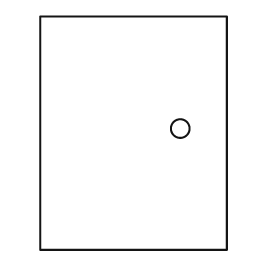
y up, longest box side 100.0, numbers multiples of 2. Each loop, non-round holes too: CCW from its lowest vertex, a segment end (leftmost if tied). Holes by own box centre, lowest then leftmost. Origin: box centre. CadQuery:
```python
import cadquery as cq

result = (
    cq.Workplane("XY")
    .moveTo(-40.0, -50.0)
    .lineTo(40.0, -50.0)
    .lineTo(40.0, 50.0)
    .lineTo(-40.0, 50.0)
    .close()
    .moveTo(20.0, 2.0)
    .circle(4.0)
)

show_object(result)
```